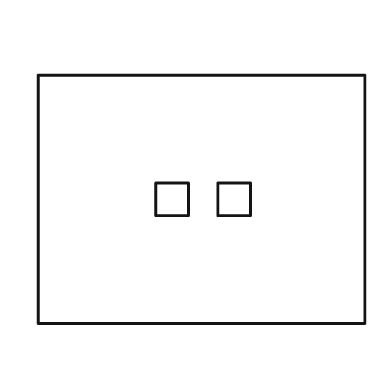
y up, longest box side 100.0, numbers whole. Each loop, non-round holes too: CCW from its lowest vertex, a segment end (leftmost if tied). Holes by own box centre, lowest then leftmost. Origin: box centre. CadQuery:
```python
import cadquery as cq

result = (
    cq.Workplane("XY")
    .moveTo(-50.0, -38.0)
    .lineTo(50.0, -38.0)
    .lineTo(50.0, 38.0)
    .lineTo(-50.0, 38.0)
    .close()
    .moveTo(-14.0, -5.0)
    .lineTo(-4.0, -5.0)
    .lineTo(-4.0, 5.0)
    .lineTo(-14.0, 5.0)
    .close()
    .moveTo(5.0, -5.0)
    .lineTo(15.0, -5.0)
    .lineTo(15.0, 5.0)
    .lineTo(5.0, 5.0)
    .close()
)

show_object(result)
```